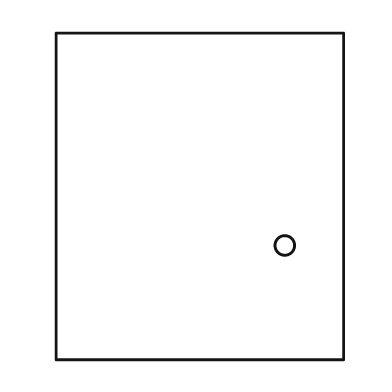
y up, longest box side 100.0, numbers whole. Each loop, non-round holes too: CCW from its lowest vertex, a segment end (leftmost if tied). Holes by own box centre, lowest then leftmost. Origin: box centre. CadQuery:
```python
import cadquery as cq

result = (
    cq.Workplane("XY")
    .moveTo(-44.0, -50.0)
    .lineTo(44.0, -50.0)
    .lineTo(44.0, 50.0)
    .lineTo(-44.0, 50.0)
    .close()
    .moveTo(26.0, -15.0)
    .circle(3.0)
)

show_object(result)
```